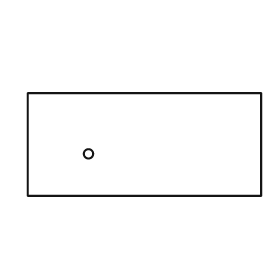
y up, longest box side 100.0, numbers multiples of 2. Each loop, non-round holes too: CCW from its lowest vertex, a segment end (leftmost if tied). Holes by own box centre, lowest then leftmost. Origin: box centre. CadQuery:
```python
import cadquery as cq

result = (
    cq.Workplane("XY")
    .moveTo(-50.0, -22.0)
    .lineTo(50.0, -22.0)
    .lineTo(50.0, 22.0)
    .lineTo(-50.0, 22.0)
    .close()
    .moveTo(-24.0, -4.0)
    .circle(2.0)
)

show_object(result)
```